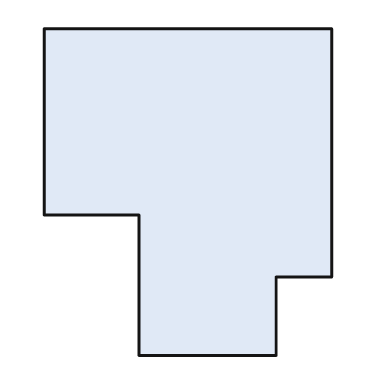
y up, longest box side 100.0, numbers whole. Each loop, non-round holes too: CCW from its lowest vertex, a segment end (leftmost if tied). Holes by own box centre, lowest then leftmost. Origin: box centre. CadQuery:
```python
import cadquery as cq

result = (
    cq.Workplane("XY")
    .moveTo(-15.0, -50.0)
    .lineTo(27.0, -50.0)
    .lineTo(27.0, -26.0)
    .lineTo(44.0, -26.0)
    .lineTo(44.0, 50.0)
    .lineTo(-44.0, 50.0)
    .lineTo(-44.0, -7.0)
    .lineTo(-15.0, -7.0)
    .close()
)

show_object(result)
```